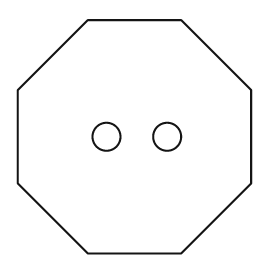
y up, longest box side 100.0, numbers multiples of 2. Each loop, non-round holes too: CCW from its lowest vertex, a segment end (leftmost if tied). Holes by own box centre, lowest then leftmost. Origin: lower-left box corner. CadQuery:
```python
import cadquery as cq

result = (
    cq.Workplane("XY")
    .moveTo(30.0, 0.0)
    .lineTo(70.0, 0.0)
    .lineTo(100.0, 30.0)
    .lineTo(100.0, 70.0)
    .lineTo(70.0, 100.0)
    .lineTo(30.0, 100.0)
    .lineTo(0.0, 70.0)
    .lineTo(0.0, 30.0)
    .close()
    .moveTo(38.0, 50.0)
    .circle(6.0)
    .moveTo(64.0, 50.0)
    .circle(6.0)
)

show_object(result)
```